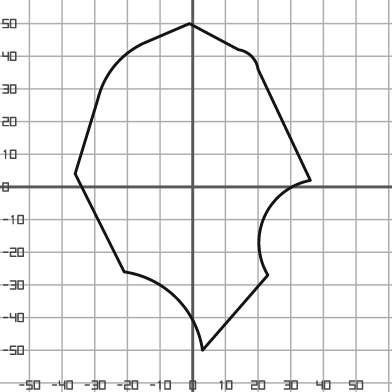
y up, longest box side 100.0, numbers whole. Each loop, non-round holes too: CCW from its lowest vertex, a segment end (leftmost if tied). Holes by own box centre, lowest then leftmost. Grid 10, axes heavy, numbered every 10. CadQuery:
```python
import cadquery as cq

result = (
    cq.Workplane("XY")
    .moveTo(3.0, -50.0)
    .lineTo(23.0, -27.0)
    .threePointArc((22.0, -9.0), (36.0, 2.0))
    .lineTo(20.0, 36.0)
    .threePointArc((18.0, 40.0), (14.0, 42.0))
    .lineTo(-1.0, 50.0)
    .lineTo(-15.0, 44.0)
    .threePointArc((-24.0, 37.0), (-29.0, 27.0))
    .lineTo(-36.0, 4.0)
    .lineTo(-21.0, -26.0)
    .threePointArc((-5.0, -34.0), (3.0, -50.0))
    .close()
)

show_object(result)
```